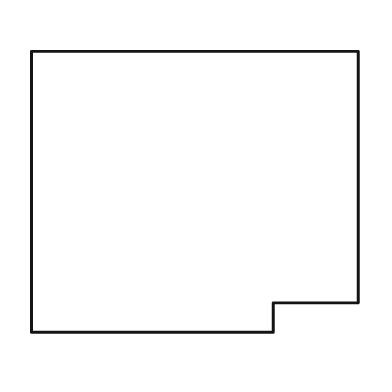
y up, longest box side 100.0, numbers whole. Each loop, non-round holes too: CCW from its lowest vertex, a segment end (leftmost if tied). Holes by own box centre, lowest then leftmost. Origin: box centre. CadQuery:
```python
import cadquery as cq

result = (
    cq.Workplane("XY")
    .moveTo(-50.0, -43.0)
    .lineTo(24.0, -43.0)
    .lineTo(24.0, -34.0)
    .lineTo(50.0, -34.0)
    .lineTo(50.0, 43.0)
    .lineTo(-50.0, 43.0)
    .close()
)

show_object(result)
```